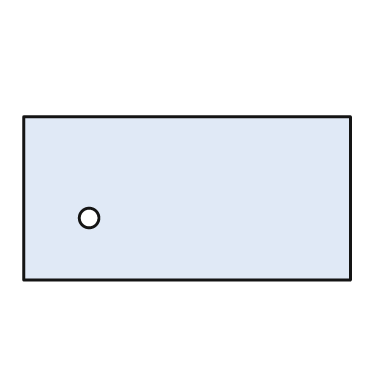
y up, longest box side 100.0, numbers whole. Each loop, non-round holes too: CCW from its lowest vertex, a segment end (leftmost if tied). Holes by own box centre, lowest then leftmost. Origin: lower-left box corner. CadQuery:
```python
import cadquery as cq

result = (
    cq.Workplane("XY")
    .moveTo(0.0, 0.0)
    .lineTo(100.0, 0.0)
    .lineTo(100.0, 50.0)
    .lineTo(0.0, 50.0)
    .close()
    .moveTo(20.0, 19.0)
    .circle(3.0)
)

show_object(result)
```